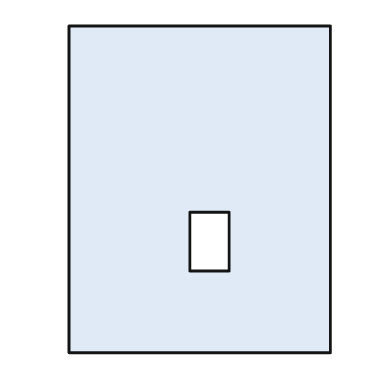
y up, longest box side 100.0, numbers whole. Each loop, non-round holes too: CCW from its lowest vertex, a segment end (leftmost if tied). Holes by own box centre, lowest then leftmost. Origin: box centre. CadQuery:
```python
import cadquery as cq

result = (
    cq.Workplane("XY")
    .moveTo(-40.0, -50.0)
    .lineTo(40.0, -50.0)
    .lineTo(40.0, 50.0)
    .lineTo(-40.0, 50.0)
    .close()
    .moveTo(-3.0, -25.0)
    .lineTo(9.0, -25.0)
    .lineTo(9.0, -7.0)
    .lineTo(-3.0, -7.0)
    .close()
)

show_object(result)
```